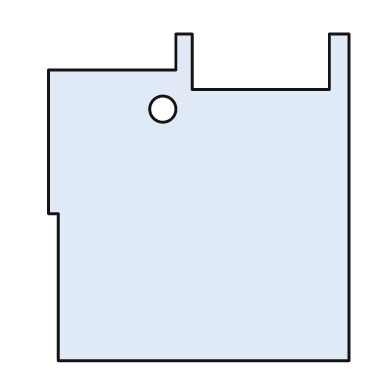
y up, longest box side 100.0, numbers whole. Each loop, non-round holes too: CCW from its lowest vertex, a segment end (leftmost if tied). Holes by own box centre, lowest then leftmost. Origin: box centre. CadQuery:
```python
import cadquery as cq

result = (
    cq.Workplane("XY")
    .moveTo(-43.0, -50.0)
    .lineTo(46.0, -50.0)
    .lineTo(46.0, 50.0)
    .lineTo(40.0, 50.0)
    .lineTo(40.0, 33.0)
    .lineTo(-2.0, 33.0)
    .lineTo(-2.0, 50.0)
    .lineTo(-7.0, 50.0)
    .lineTo(-7.0, 39.0)
    .lineTo(-46.0, 39.0)
    .lineTo(-46.0, -5.0)
    .lineTo(-43.0, -5.0)
    .close()
    .moveTo(-11.0, 27.0)
    .circle(4.0)
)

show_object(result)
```